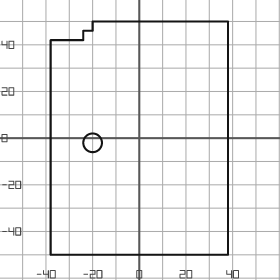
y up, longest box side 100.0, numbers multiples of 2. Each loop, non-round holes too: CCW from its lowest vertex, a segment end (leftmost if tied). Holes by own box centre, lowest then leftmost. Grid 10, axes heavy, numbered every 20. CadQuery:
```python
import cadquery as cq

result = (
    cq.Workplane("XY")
    .moveTo(-38.0, -50.0)
    .lineTo(38.0, -50.0)
    .lineTo(38.0, 50.0)
    .lineTo(-20.0, 50.0)
    .lineTo(-20.0, 46.0)
    .lineTo(-24.0, 46.0)
    .lineTo(-24.0, 42.0)
    .lineTo(-38.0, 42.0)
    .close()
    .moveTo(-20.0, -2.0)
    .circle(4.0)
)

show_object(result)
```